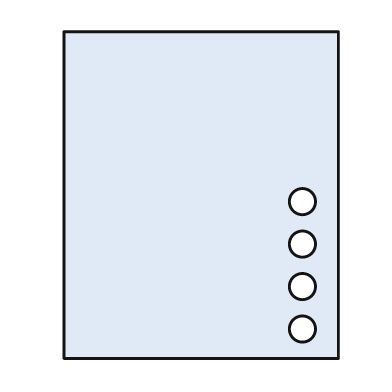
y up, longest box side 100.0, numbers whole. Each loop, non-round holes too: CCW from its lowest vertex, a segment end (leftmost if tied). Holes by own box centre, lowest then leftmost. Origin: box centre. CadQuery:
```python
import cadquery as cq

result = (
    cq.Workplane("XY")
    .moveTo(-42.0, -50.0)
    .lineTo(42.0, -50.0)
    .lineTo(42.0, 50.0)
    .lineTo(-42.0, 50.0)
    .close()
    .moveTo(31.0, -41.0)
    .circle(4.0)
    .moveTo(31.0, -28.0)
    .circle(4.0)
    .moveTo(31.0, -15.0)
    .circle(4.0)
    .moveTo(31.0, -2.0)
    .circle(4.0)
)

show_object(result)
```